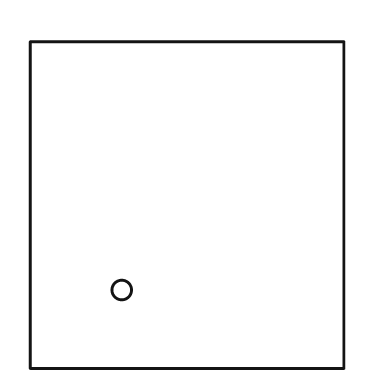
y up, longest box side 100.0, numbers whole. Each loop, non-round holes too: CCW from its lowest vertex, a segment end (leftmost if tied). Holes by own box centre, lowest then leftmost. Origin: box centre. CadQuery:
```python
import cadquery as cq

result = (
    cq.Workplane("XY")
    .moveTo(-48.0, -50.0)
    .lineTo(48.0, -50.0)
    .lineTo(48.0, 50.0)
    .lineTo(-48.0, 50.0)
    .close()
    .moveTo(-20.0, -26.0)
    .circle(3.0)
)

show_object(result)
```